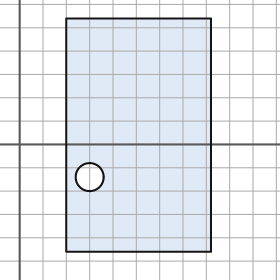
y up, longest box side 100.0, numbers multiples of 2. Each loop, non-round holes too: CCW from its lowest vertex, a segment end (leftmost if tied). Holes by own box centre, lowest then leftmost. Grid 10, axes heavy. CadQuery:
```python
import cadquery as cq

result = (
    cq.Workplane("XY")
    .moveTo(20.0, -46.0)
    .lineTo(82.0, -46.0)
    .lineTo(82.0, 54.0)
    .lineTo(20.0, 54.0)
    .close()
    .moveTo(30.0, -14.0)
    .circle(6.0)
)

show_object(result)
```